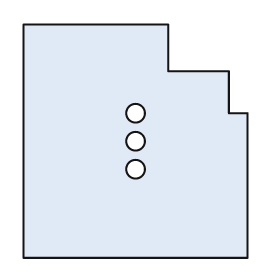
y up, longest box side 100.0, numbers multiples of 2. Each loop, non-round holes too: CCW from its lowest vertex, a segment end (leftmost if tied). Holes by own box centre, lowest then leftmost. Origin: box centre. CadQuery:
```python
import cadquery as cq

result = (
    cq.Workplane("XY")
    .moveTo(-48.0, -50.0)
    .lineTo(48.0, -50.0)
    .lineTo(48.0, 12.0)
    .lineTo(40.0, 12.0)
    .lineTo(40.0, 30.0)
    .lineTo(14.0, 30.0)
    .lineTo(14.0, 50.0)
    .lineTo(-48.0, 50.0)
    .close()
    .moveTo(0.0, -12.0)
    .circle(4.0)
    .moveTo(0.0, 0.0)
    .circle(4.0)
    .moveTo(0.0, 12.0)
    .circle(4.0)
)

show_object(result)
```